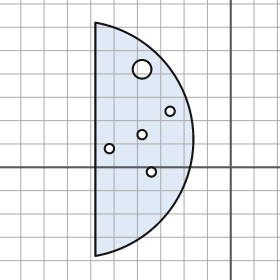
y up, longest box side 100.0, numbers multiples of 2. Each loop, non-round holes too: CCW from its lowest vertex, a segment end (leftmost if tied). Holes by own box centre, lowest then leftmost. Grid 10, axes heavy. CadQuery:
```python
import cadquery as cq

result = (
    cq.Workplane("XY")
    .moveTo(-58.0, -38.0)
    .threePointArc((-16.0, 12.0), (-58.0, 62.0))
    .close()
    .moveTo(-34.0, -2.0)
    .circle(2.0)
    .moveTo(-52.0, 8.0)
    .circle(2.0)
    .moveTo(-38.0, 14.0)
    .circle(2.0)
    .moveTo(-26.0, 24.0)
    .circle(2.0)
    .moveTo(-38.0, 42.0)
    .circle(4.0)
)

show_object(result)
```